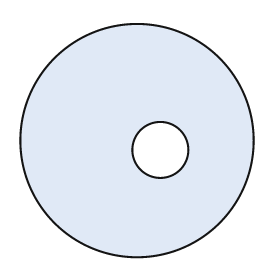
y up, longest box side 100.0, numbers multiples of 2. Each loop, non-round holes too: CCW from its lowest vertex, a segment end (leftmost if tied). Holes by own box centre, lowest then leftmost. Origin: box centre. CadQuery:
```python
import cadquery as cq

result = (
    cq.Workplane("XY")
    .moveTo(0.0, 0.0)
    .circle(50.0)
    .moveTo(10.0, -4.0)
    .circle(12.0)
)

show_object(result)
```